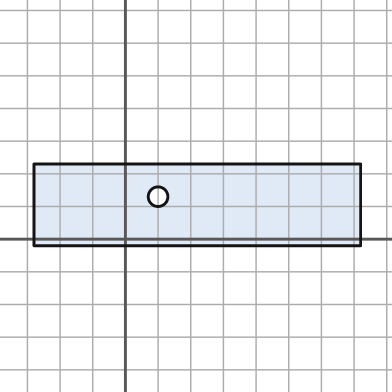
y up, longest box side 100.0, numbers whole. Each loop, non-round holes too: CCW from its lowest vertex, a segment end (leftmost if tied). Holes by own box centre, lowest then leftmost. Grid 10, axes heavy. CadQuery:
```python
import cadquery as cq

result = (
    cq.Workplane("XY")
    .moveTo(-28.0, -2.0)
    .lineTo(72.0, -2.0)
    .lineTo(72.0, 23.0)
    .lineTo(-28.0, 23.0)
    .close()
    .moveTo(10.0, 13.0)
    .circle(3.0)
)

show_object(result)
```